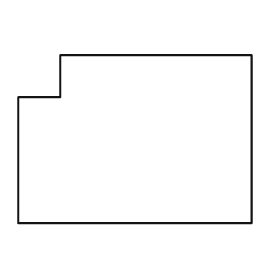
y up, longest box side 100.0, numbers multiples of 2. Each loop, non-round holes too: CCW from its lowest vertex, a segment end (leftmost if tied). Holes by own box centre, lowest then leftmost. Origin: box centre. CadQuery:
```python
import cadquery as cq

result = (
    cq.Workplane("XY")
    .moveTo(-50.0, -36.0)
    .lineTo(50.0, -36.0)
    .lineTo(50.0, 36.0)
    .lineTo(-32.0, 36.0)
    .lineTo(-32.0, 18.0)
    .lineTo(-50.0, 18.0)
    .close()
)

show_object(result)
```